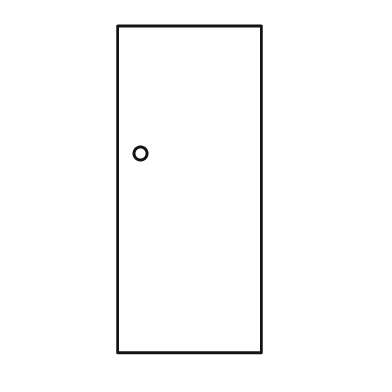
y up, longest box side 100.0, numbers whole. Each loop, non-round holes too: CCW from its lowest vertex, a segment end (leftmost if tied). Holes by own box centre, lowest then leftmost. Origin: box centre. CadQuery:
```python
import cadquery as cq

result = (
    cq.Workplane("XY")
    .moveTo(-22.0, -50.0)
    .lineTo(22.0, -50.0)
    .lineTo(22.0, 50.0)
    .lineTo(-22.0, 50.0)
    .close()
    .moveTo(-15.0, 11.0)
    .circle(2.0)
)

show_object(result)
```